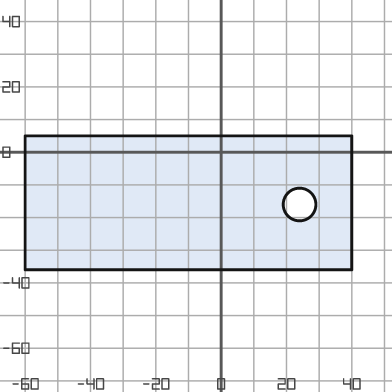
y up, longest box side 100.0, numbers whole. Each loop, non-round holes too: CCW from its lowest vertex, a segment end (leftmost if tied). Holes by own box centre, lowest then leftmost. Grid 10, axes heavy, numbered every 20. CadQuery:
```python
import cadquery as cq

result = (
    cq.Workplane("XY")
    .moveTo(-60.0, -36.0)
    .lineTo(40.0, -36.0)
    .lineTo(40.0, 5.0)
    .lineTo(-60.0, 5.0)
    .close()
    .moveTo(24.0, -16.0)
    .circle(5.0)
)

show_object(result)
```